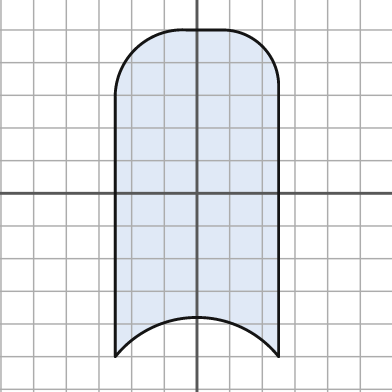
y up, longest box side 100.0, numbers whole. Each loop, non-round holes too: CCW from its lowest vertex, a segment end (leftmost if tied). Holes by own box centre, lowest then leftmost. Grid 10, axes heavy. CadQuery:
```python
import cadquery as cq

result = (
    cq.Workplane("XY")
    .moveTo(-25.0, -50.0)
    .threePointArc((0.0, -38.0), (25.0, -50.0))
    .lineTo(25.0, 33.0)
    .threePointArc((20.0, 45.0), (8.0, 50.0))
    .lineTo(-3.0, 50.0)
    .threePointArc((-19.0, 44.0), (-25.0, 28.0))
    .close()
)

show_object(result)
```